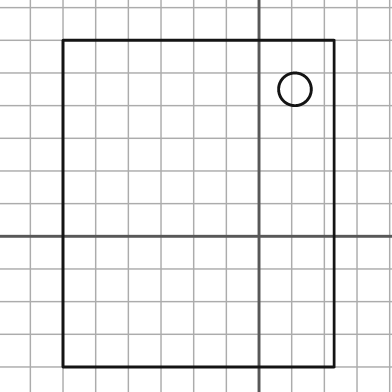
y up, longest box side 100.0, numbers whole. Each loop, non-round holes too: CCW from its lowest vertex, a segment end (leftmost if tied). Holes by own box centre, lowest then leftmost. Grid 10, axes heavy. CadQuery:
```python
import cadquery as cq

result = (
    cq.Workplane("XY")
    .moveTo(-60.0, -40.0)
    .lineTo(23.0, -40.0)
    .lineTo(23.0, 60.0)
    .lineTo(-60.0, 60.0)
    .close()
    .moveTo(11.0, 45.0)
    .circle(5.0)
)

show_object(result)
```